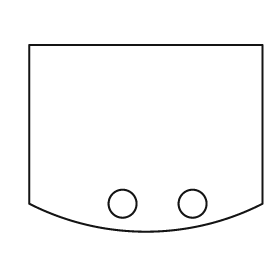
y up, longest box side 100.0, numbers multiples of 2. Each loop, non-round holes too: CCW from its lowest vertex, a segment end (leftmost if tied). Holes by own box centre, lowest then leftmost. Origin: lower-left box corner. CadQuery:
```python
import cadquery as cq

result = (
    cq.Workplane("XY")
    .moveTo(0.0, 12.0)
    .threePointArc((50.0, 0.0), (100.0, 12.0))
    .lineTo(100.0, 80.0)
    .lineTo(0.0, 80.0)
    .close()
    .moveTo(40.0, 12.0)
    .circle(6.0)
    .moveTo(70.0, 12.0)
    .circle(6.0)
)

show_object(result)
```